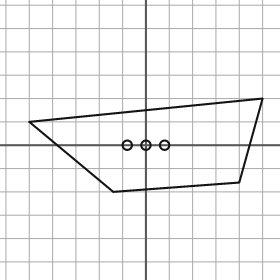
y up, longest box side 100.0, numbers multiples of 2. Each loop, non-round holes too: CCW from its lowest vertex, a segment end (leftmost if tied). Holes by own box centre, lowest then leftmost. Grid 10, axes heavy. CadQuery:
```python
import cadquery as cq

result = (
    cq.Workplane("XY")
    .moveTo(-14.0, -20.0)
    .lineTo(40.0, -16.0)
    .lineTo(50.0, 20.0)
    .lineTo(-50.0, 10.0)
    .close()
    .moveTo(-8.0, 0.0)
    .circle(2.0)
    .moveTo(0.0, 0.0)
    .circle(2.0)
    .moveTo(8.0, 0.0)
    .circle(2.0)
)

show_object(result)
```